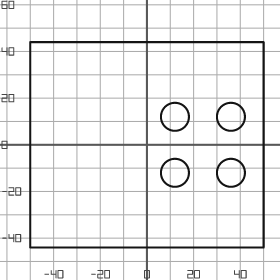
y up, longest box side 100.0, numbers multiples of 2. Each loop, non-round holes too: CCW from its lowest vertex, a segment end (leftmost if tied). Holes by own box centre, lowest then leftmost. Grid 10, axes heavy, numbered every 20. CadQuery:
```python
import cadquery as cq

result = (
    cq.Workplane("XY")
    .moveTo(-50.0, -44.0)
    .lineTo(50.0, -44.0)
    .lineTo(50.0, 44.0)
    .lineTo(-50.0, 44.0)
    .close()
    .moveTo(12.0, -12.0)
    .circle(6.0)
    .moveTo(36.0, -12.0)
    .circle(6.0)
    .moveTo(12.0, 12.0)
    .circle(6.0)
    .moveTo(36.0, 12.0)
    .circle(6.0)
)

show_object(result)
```